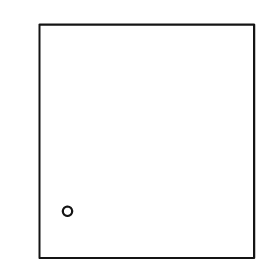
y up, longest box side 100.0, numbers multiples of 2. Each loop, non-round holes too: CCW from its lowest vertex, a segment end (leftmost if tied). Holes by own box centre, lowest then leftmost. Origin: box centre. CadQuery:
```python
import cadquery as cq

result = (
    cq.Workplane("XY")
    .moveTo(-46.0, -50.0)
    .lineTo(46.0, -50.0)
    .lineTo(46.0, 50.0)
    .lineTo(-46.0, 50.0)
    .close()
    .moveTo(-34.0, -30.0)
    .circle(2.0)
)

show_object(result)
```